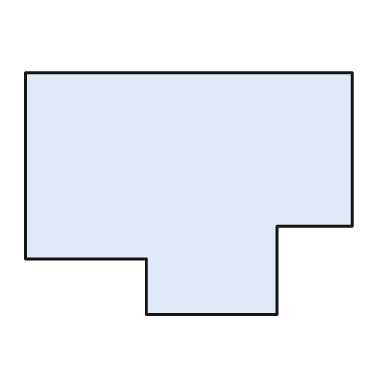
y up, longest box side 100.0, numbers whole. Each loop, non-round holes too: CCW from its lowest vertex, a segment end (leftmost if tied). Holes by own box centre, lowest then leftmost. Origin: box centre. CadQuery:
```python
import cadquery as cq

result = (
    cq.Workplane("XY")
    .moveTo(-13.0, -37.0)
    .lineTo(27.0, -37.0)
    .lineTo(27.0, -10.0)
    .lineTo(50.0, -10.0)
    .lineTo(50.0, 37.0)
    .lineTo(-50.0, 37.0)
    .lineTo(-50.0, -20.0)
    .lineTo(-13.0, -20.0)
    .close()
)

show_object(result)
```